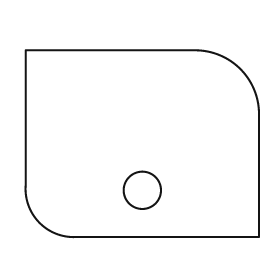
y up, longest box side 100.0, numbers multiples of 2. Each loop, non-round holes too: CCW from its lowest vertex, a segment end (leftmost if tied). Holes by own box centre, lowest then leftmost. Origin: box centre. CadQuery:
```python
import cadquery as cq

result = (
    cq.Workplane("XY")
    .moveTo(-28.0, -40.0)
    .lineTo(50.0, -40.0)
    .lineTo(50.0, 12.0)
    .threePointArc((42.0, 32.0), (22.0, 40.0))
    .lineTo(-50.0, 40.0)
    .lineTo(-50.0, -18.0)
    .threePointArc((-44.0, -34.0), (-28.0, -40.0))
    .close()
    .moveTo(0.0, -20.0)
    .circle(8.0)
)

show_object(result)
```